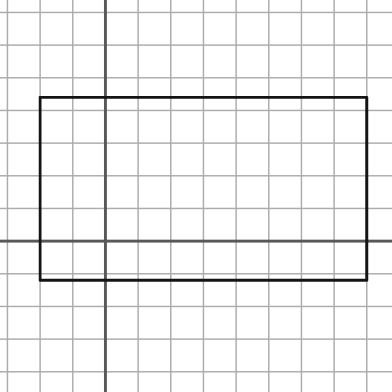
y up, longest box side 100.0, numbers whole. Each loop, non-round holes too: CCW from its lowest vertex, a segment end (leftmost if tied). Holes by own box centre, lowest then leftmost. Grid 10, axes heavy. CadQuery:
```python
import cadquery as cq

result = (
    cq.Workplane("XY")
    .moveTo(-20.0, -12.0)
    .lineTo(80.0, -12.0)
    .lineTo(80.0, 44.0)
    .lineTo(-20.0, 44.0)
    .close()
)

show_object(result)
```